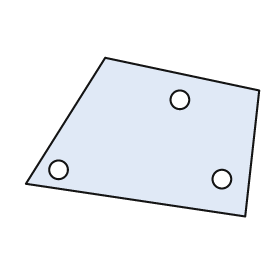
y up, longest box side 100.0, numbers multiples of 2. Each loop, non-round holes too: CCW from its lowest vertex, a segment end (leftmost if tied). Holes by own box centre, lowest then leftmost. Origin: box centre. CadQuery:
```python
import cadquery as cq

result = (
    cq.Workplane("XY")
    .moveTo(44.0, -34.0)
    .lineTo(50.0, 20.0)
    .lineTo(-16.0, 34.0)
    .lineTo(-50.0, -20.0)
    .close()
    .moveTo(34.0, -18.0)
    .circle(4.0)
    .moveTo(-36.0, -14.0)
    .circle(4.0)
    .moveTo(16.0, 16.0)
    .circle(4.0)
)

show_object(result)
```